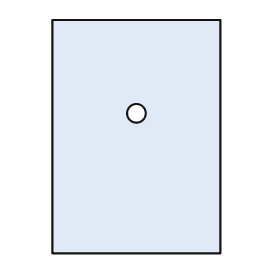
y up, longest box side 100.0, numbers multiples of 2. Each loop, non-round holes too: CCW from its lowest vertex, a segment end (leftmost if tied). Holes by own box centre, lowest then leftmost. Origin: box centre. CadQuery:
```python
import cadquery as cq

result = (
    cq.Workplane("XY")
    .moveTo(-36.0, -50.0)
    .lineTo(36.0, -50.0)
    .lineTo(36.0, 50.0)
    .lineTo(-36.0, 50.0)
    .close()
    .moveTo(0.0, 10.0)
    .circle(4.0)
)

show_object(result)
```